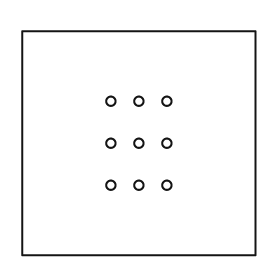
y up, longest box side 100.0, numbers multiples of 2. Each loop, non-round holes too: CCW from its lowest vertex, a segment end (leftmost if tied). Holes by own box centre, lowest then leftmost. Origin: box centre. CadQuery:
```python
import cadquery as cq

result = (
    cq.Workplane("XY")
    .moveTo(-50.0, -48.0)
    .lineTo(50.0, -48.0)
    .lineTo(50.0, 48.0)
    .lineTo(-50.0, 48.0)
    .close()
    .moveTo(-12.0, -18.0)
    .circle(2.0)
    .moveTo(0.0, -18.0)
    .circle(2.0)
    .moveTo(12.0, -18.0)
    .circle(2.0)
    .moveTo(-12.0, 0.0)
    .circle(2.0)
    .moveTo(0.0, 0.0)
    .circle(2.0)
    .moveTo(12.0, 0.0)
    .circle(2.0)
    .moveTo(-12.0, 18.0)
    .circle(2.0)
    .moveTo(0.0, 18.0)
    .circle(2.0)
    .moveTo(12.0, 18.0)
    .circle(2.0)
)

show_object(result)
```